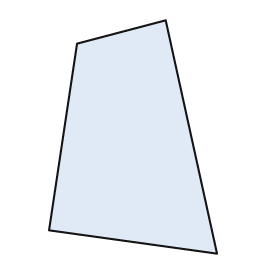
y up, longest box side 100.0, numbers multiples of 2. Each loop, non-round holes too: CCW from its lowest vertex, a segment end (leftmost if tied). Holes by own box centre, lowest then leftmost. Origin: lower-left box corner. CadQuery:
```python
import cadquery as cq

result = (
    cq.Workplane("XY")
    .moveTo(72.0, 0.0)
    .lineTo(50.0, 100.0)
    .lineTo(12.0, 90.0)
    .lineTo(0.0, 10.0)
    .close()
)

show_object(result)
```